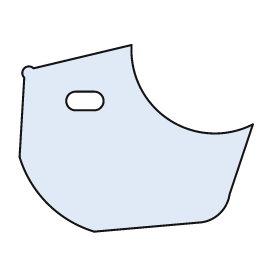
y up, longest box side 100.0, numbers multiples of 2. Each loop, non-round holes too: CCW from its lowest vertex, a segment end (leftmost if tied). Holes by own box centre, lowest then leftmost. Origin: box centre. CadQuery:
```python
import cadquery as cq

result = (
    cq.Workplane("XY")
    .moveTo(-18.0, -40.0)
    .lineTo(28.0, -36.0)
    .threePointArc((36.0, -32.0), (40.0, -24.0))
    .lineTo(50.0, 6.0)
    .threePointArc((14.0, 8.0), (-2.0, 40.0))
    .lineTo(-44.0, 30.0)
    .threePointArc((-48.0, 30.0), (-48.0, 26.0))
    .lineTo(-50.0, -8.0)
    .threePointArc((-38.0, -28.0), (-18.0, -40.0))
    .close()
    .moveTo(-26.0, 12.0)
    .lineTo(-18.0, 12.0)
    .threePointArc((-14.0, 16.0), (-18.0, 20.0))
    .lineTo(-26.0, 20.0)
    .threePointArc((-30.0, 16.0), (-26.0, 12.0))
    .close()
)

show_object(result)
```